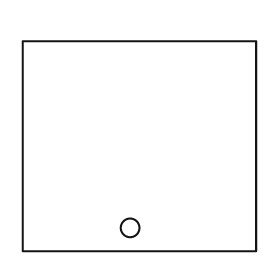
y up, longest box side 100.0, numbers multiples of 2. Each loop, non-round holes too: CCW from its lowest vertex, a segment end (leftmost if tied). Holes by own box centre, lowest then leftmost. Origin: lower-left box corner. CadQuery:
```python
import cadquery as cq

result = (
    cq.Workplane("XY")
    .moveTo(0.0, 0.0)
    .lineTo(100.0, 0.0)
    .lineTo(100.0, 90.0)
    .lineTo(0.0, 90.0)
    .close()
    .moveTo(46.0, 10.0)
    .circle(4.0)
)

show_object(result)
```